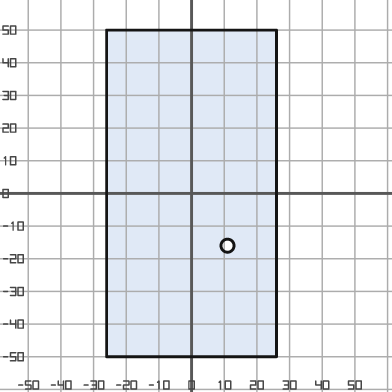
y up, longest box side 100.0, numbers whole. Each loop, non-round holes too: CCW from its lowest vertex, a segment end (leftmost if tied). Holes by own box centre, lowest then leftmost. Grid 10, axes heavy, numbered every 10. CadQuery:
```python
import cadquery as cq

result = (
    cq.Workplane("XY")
    .moveTo(-26.0, -50.0)
    .lineTo(26.0, -50.0)
    .lineTo(26.0, 50.0)
    .lineTo(-26.0, 50.0)
    .close()
    .moveTo(11.0, -16.0)
    .circle(2.0)
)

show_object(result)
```